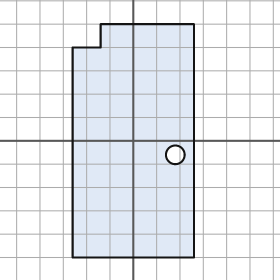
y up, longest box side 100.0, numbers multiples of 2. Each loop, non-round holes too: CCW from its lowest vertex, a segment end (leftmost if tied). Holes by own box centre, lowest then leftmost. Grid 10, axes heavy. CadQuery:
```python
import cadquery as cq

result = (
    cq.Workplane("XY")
    .moveTo(-26.0, -50.0)
    .lineTo(26.0, -50.0)
    .lineTo(26.0, 50.0)
    .lineTo(-14.0, 50.0)
    .lineTo(-14.0, 40.0)
    .lineTo(-26.0, 40.0)
    .close()
    .moveTo(18.0, -6.0)
    .circle(4.0)
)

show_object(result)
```